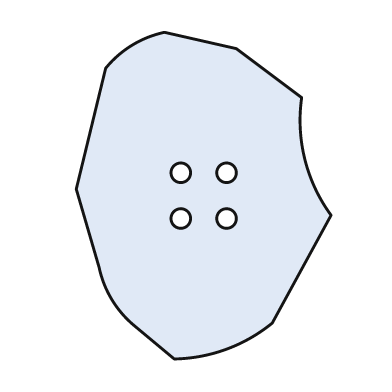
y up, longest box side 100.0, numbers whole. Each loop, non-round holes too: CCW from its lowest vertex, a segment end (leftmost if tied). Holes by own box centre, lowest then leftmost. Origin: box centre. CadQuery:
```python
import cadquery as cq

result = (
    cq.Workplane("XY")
    .moveTo(-9.0, -50.0)
    .threePointArc((7.0, -47.0), (21.0, -39.0))
    .lineTo(39.0, -6.0)
    .threePointArc((31.0, 11.0), (30.0, 30.0))
    .lineTo(10.0, 45.0)
    .lineTo(-12.0, 50.0)
    .threePointArc((-22.0, 46.0), (-30.0, 39.0))
    .lineTo(-39.0, 2.0)
    .lineTo(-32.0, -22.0)
    .threePointArc((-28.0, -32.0), (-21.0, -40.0))
    .close()
    .moveTo(-7.0, -7.0)
    .circle(3.0)
    .moveTo(7.0, -7.0)
    .circle(3.0)
    .moveTo(-7.0, 7.0)
    .circle(3.0)
    .moveTo(7.0, 7.0)
    .circle(3.0)
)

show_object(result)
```